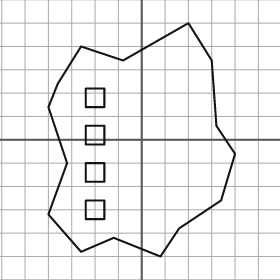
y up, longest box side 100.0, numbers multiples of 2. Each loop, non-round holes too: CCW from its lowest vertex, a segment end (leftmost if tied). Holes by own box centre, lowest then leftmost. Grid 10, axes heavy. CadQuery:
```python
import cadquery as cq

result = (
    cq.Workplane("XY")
    .moveTo(8.0, -50.0)
    .lineTo(16.0, -38.0)
    .lineTo(34.0, -26.0)
    .lineTo(40.0, -6.0)
    .lineTo(32.0, 6.0)
    .lineTo(30.0, 34.0)
    .lineTo(20.0, 50.0)
    .lineTo(-8.0, 34.0)
    .lineTo(-26.0, 40.0)
    .lineTo(-36.0, 24.0)
    .lineTo(-40.0, 14.0)
    .lineTo(-32.0, -10.0)
    .lineTo(-40.0, -32.0)
    .lineTo(-26.0, -48.0)
    .lineTo(-12.0, -42.0)
    .close()
    .moveTo(-24.0, -34.0)
    .lineTo(-16.0, -34.0)
    .lineTo(-16.0, -26.0)
    .lineTo(-24.0, -26.0)
    .close()
    .moveTo(-24.0, -18.0)
    .lineTo(-16.0, -18.0)
    .lineTo(-16.0, -10.0)
    .lineTo(-24.0, -10.0)
    .close()
    .moveTo(-24.0, -2.0)
    .lineTo(-16.0, -2.0)
    .lineTo(-16.0, 6.0)
    .lineTo(-24.0, 6.0)
    .close()
    .moveTo(-24.0, 14.0)
    .lineTo(-16.0, 14.0)
    .lineTo(-16.0, 22.0)
    .lineTo(-24.0, 22.0)
    .close()
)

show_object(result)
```